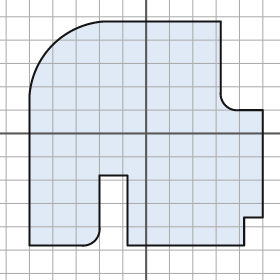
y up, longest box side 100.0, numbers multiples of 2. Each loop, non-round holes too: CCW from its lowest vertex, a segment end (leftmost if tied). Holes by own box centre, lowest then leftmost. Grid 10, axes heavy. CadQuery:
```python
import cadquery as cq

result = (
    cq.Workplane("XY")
    .moveTo(-50.0, -48.0)
    .lineTo(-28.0, -48.0)
    .threePointArc((-22.0, -46.0), (-20.0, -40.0))
    .lineTo(-20.0, -18.0)
    .lineTo(-8.0, -18.0)
    .lineTo(-8.0, -48.0)
    .lineTo(42.0, -48.0)
    .lineTo(42.0, -36.0)
    .lineTo(50.0, -36.0)
    .lineTo(50.0, 10.0)
    .lineTo(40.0, 10.0)
    .threePointArc((34.0, 12.0), (32.0, 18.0))
    .lineTo(32.0, 48.0)
    .lineTo(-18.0, 48.0)
    .threePointArc((-40.0, 38.0), (-50.0, 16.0))
    .close()
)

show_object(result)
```